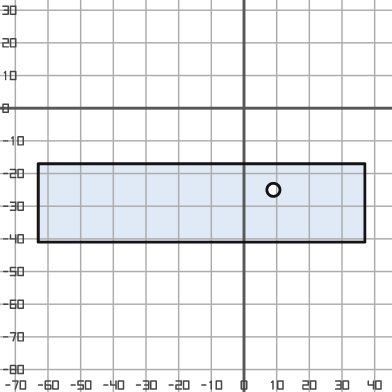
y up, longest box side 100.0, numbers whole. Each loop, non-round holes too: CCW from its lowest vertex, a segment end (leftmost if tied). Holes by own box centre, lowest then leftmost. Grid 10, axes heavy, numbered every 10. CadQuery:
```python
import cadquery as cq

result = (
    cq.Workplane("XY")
    .moveTo(-63.0, -41.0)
    .lineTo(37.0, -41.0)
    .lineTo(37.0, -17.0)
    .lineTo(-63.0, -17.0)
    .close()
    .moveTo(9.0, -25.0)
    .circle(2.0)
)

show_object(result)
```